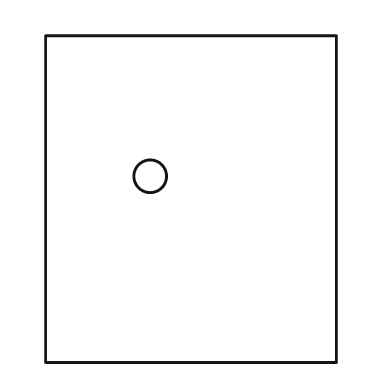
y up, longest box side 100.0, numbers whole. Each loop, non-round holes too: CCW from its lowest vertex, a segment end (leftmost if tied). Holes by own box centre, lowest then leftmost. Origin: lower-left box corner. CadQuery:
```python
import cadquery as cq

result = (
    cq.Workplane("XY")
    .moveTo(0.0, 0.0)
    .lineTo(89.0, 0.0)
    .lineTo(89.0, 100.0)
    .lineTo(0.0, 100.0)
    .close()
    .moveTo(32.0, 57.0)
    .circle(5.0)
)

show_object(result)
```